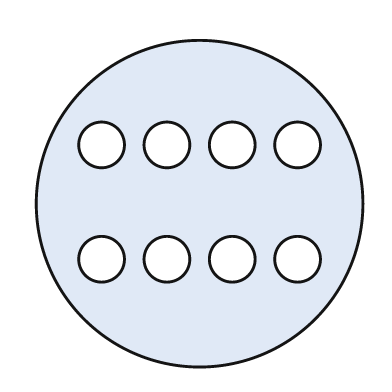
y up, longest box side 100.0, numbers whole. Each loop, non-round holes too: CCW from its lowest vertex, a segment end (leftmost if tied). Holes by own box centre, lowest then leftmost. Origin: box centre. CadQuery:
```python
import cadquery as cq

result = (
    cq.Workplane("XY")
    .moveTo(0.0, 0.0)
    .circle(50.0)
    .moveTo(-30.0, -17.0)
    .circle(7.0)
    .moveTo(-10.0, -17.0)
    .circle(7.0)
    .moveTo(10.0, -17.0)
    .circle(7.0)
    .moveTo(30.0, -17.0)
    .circle(7.0)
    .moveTo(-30.0, 18.0)
    .circle(7.0)
    .moveTo(-10.0, 18.0)
    .circle(7.0)
    .moveTo(10.0, 18.0)
    .circle(7.0)
    .moveTo(30.0, 18.0)
    .circle(7.0)
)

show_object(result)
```